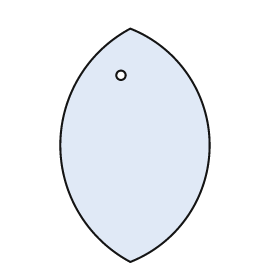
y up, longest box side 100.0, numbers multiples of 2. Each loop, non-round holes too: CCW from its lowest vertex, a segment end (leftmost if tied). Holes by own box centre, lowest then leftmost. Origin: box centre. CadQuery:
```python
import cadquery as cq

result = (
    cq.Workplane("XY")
    .moveTo(-2.0, -50.0)
    .threePointArc((32.0, 0.0), (-2.0, 50.0))
    .threePointArc((-32.0, 0.0), (-2.0, -50.0))
    .close()
    .moveTo(-6.0, 30.0)
    .circle(2.0)
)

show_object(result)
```